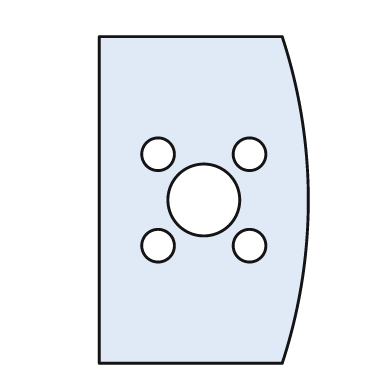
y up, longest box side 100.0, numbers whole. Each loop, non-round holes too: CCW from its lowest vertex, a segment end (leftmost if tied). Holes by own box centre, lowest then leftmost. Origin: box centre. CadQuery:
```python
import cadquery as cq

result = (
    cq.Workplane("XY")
    .moveTo(-32.0, -50.0)
    .lineTo(24.0, -50.0)
    .threePointArc((32.0, 0.0), (24.0, 50.0))
    .lineTo(-32.0, 50.0)
    .close()
    .moveTo(-14.0, -14.0)
    .circle(5.0)
    .moveTo(14.0, -14.0)
    .circle(5.0)
    .moveTo(0.0, 0.0)
    .circle(11.0)
    .moveTo(-14.0, 14.0)
    .circle(5.0)
    .moveTo(14.0, 14.0)
    .circle(5.0)
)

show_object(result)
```